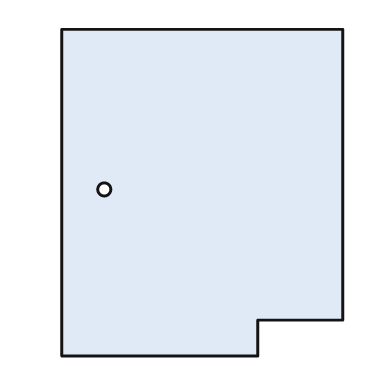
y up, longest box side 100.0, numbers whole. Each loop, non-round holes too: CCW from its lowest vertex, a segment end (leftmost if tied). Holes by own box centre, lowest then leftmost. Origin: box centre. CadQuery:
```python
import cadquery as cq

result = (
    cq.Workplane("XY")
    .moveTo(-43.0, -50.0)
    .lineTo(17.0, -50.0)
    .lineTo(17.0, -39.0)
    .lineTo(43.0, -39.0)
    .lineTo(43.0, 50.0)
    .lineTo(-43.0, 50.0)
    .close()
    .moveTo(-30.0, 1.0)
    .circle(2.0)
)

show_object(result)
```